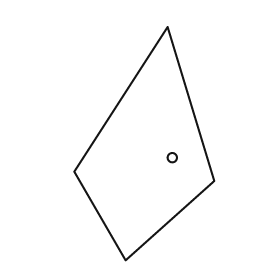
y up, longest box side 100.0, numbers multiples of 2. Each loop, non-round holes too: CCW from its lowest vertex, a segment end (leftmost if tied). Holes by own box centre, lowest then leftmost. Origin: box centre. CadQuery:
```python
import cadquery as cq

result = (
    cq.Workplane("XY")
    .moveTo(-8.0, -50.0)
    .lineTo(30.0, -16.0)
    .lineTo(10.0, 50.0)
    .lineTo(-30.0, -12.0)
    .close()
    .moveTo(12.0, -6.0)
    .circle(2.0)
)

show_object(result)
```